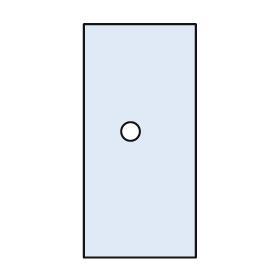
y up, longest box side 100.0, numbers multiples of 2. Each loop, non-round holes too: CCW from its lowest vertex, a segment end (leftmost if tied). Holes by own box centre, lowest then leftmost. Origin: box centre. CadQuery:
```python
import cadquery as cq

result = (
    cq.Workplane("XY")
    .moveTo(-24.0, -50.0)
    .lineTo(24.0, -50.0)
    .lineTo(24.0, 50.0)
    .lineTo(-24.0, 50.0)
    .close()
    .moveTo(-4.0, 4.0)
    .circle(4.0)
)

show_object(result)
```